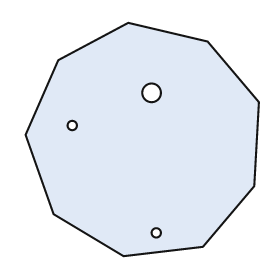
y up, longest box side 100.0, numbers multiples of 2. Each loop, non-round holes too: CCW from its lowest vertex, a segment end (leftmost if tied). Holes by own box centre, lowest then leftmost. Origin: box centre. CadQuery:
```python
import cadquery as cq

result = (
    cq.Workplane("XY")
    .moveTo(-8.0, -50.0)
    .lineTo(26.0, -46.0)
    .lineTo(48.0, -20.0)
    .lineTo(50.0, 16.0)
    .lineTo(28.0, 42.0)
    .lineTo(-6.0, 50.0)
    .lineTo(-36.0, 34.0)
    .lineTo(-50.0, 2.0)
    .lineTo(-38.0, -32.0)
    .close()
    .moveTo(6.0, -40.0)
    .circle(2.0)
    .moveTo(-30.0, 6.0)
    .circle(2.0)
    .moveTo(4.0, 20.0)
    .circle(4.0)
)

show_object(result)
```